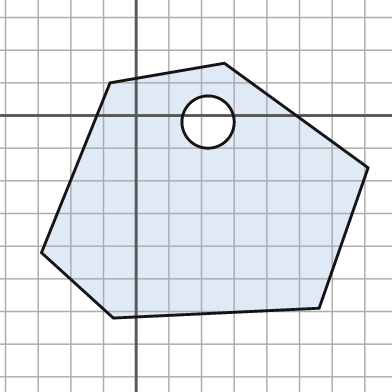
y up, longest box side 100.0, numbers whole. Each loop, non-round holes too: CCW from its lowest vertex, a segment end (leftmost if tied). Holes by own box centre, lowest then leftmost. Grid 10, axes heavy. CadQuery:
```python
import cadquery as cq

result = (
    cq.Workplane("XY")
    .moveTo(-7.0, -62.0)
    .lineTo(56.0, -59.0)
    .lineTo(71.0, -16.0)
    .lineTo(27.0, 16.0)
    .lineTo(-8.0, 10.0)
    .lineTo(-29.0, -42.0)
    .close()
    .moveTo(22.0, -2.0)
    .circle(8.0)
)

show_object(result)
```